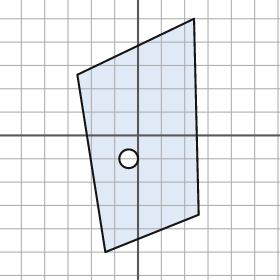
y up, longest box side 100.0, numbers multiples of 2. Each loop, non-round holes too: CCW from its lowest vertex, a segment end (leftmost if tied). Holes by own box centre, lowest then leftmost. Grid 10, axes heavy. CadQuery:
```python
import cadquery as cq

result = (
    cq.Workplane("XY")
    .moveTo(-14.0, -50.0)
    .lineTo(26.0, -34.0)
    .lineTo(24.0, 50.0)
    .lineTo(-26.0, 26.0)
    .close()
    .moveTo(-4.0, -10.0)
    .circle(4.0)
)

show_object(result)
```